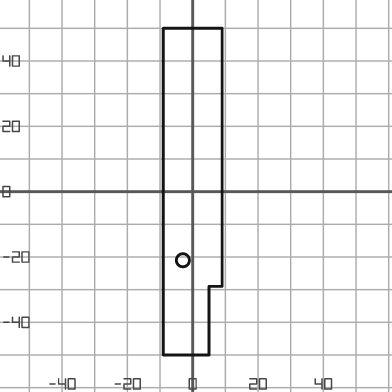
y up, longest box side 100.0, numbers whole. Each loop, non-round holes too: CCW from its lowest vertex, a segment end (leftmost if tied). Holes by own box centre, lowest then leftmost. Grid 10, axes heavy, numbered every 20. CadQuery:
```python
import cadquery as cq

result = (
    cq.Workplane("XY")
    .moveTo(-9.0, -50.0)
    .lineTo(5.0, -50.0)
    .lineTo(5.0, -29.0)
    .lineTo(9.0, -29.0)
    .lineTo(9.0, 50.0)
    .lineTo(-9.0, 50.0)
    .close()
    .moveTo(-3.0, -21.0)
    .circle(2.0)
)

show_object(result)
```